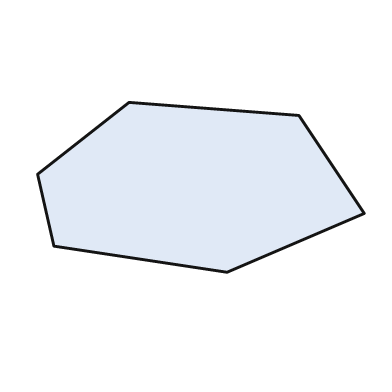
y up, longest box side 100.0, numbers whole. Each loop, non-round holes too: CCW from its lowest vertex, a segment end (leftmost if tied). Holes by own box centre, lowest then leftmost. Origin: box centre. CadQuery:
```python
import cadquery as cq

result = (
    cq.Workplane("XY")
    .moveTo(8.0, -26.0)
    .lineTo(50.0, -8.0)
    .lineTo(30.0, 22.0)
    .lineTo(-22.0, 26.0)
    .lineTo(-50.0, 4.0)
    .lineTo(-45.0, -18.0)
    .close()
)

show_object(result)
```